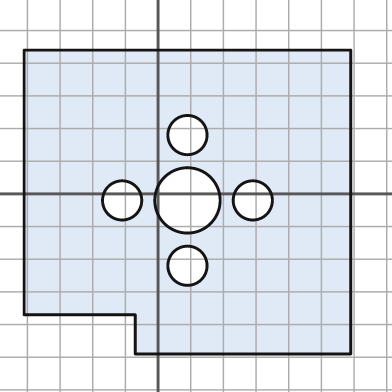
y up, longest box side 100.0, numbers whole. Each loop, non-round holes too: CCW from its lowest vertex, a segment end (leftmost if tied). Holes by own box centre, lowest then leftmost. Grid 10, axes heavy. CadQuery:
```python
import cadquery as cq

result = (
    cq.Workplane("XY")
    .moveTo(-7.0, -49.0)
    .lineTo(59.0, -49.0)
    .lineTo(59.0, 44.0)
    .lineTo(-41.0, 44.0)
    .lineTo(-41.0, -37.0)
    .lineTo(-7.0, -37.0)
    .close()
    .moveTo(9.0, -22.0)
    .circle(6.0)
    .moveTo(-11.0, -2.0)
    .circle(6.0)
    .moveTo(9.0, -2.0)
    .circle(10.0)
    .moveTo(29.0, -2.0)
    .circle(6.0)
    .moveTo(9.0, 18.0)
    .circle(6.0)
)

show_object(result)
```